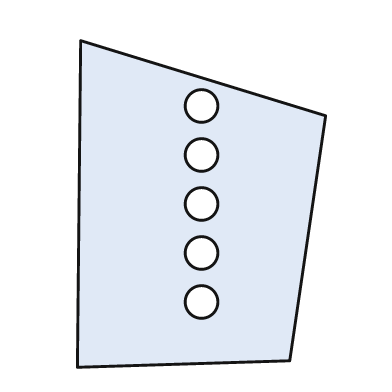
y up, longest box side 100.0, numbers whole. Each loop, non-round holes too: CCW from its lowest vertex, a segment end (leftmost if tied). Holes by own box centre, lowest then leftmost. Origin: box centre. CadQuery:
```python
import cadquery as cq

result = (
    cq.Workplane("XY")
    .moveTo(-38.0, -50.0)
    .lineTo(27.0, -48.0)
    .lineTo(38.0, 27.0)
    .lineTo(-37.0, 50.0)
    .close()
    .moveTo(0.0, -30.0)
    .circle(5.0)
    .moveTo(0.0, -15.0)
    .circle(5.0)
    .moveTo(0.0, 0.0)
    .circle(5.0)
    .moveTo(0.0, 15.0)
    .circle(5.0)
    .moveTo(0.0, 30.0)
    .circle(5.0)
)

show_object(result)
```